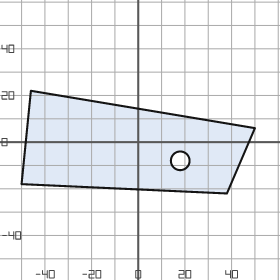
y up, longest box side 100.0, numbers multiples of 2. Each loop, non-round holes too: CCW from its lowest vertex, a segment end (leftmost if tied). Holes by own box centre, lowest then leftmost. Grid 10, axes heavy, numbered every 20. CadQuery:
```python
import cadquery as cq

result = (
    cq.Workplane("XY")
    .moveTo(38.0, -22.0)
    .lineTo(50.0, 6.0)
    .lineTo(-46.0, 22.0)
    .lineTo(-50.0, -18.0)
    .close()
    .moveTo(18.0, -8.0)
    .circle(4.0)
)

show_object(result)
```